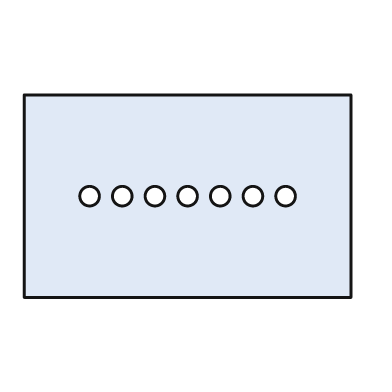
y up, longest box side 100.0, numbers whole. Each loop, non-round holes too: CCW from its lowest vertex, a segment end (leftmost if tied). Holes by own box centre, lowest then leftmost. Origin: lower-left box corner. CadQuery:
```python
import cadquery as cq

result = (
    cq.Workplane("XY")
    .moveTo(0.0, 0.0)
    .lineTo(100.0, 0.0)
    .lineTo(100.0, 62.0)
    .lineTo(0.0, 62.0)
    .close()
    .moveTo(20.0, 31.0)
    .circle(3.0)
    .moveTo(30.0, 31.0)
    .circle(3.0)
    .moveTo(40.0, 31.0)
    .circle(3.0)
    .moveTo(50.0, 31.0)
    .circle(3.0)
    .moveTo(60.0, 31.0)
    .circle(3.0)
    .moveTo(70.0, 31.0)
    .circle(3.0)
    .moveTo(80.0, 31.0)
    .circle(3.0)
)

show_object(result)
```